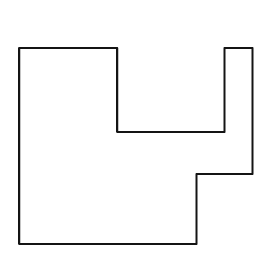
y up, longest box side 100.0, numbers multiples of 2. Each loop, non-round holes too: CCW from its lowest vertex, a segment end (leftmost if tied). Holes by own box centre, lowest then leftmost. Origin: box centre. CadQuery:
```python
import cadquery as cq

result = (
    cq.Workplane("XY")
    .moveTo(-50.0, -42.0)
    .lineTo(26.0, -42.0)
    .lineTo(26.0, -12.0)
    .lineTo(50.0, -12.0)
    .lineTo(50.0, 42.0)
    .lineTo(38.0, 42.0)
    .lineTo(38.0, 6.0)
    .lineTo(-8.0, 6.0)
    .lineTo(-8.0, 42.0)
    .lineTo(-50.0, 42.0)
    .close()
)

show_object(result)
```